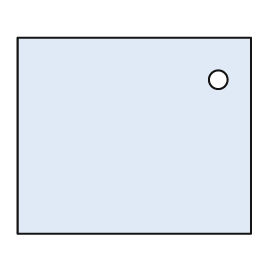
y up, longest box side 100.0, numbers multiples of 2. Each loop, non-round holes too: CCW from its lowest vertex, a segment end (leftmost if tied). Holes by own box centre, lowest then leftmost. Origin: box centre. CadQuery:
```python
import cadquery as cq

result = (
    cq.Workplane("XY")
    .moveTo(-50.0, -42.0)
    .lineTo(50.0, -42.0)
    .lineTo(50.0, 42.0)
    .lineTo(-50.0, 42.0)
    .close()
    .moveTo(36.0, 24.0)
    .circle(4.0)
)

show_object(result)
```